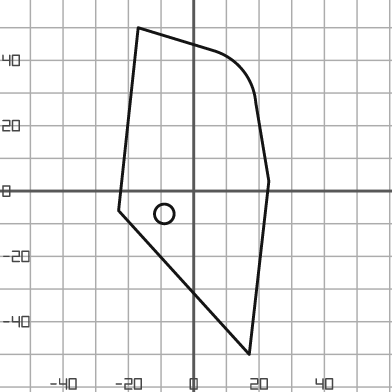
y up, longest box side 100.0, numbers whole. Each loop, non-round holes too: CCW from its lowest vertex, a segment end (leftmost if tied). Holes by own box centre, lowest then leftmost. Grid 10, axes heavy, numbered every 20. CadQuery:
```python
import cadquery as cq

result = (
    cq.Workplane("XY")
    .moveTo(17.0, -50.0)
    .lineTo(23.0, 3.0)
    .lineTo(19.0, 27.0)
    .threePointArc((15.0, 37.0), (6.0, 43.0))
    .lineTo(-17.0, 50.0)
    .lineTo(-23.0, -6.0)
    .close()
    .moveTo(-9.0, -7.0)
    .circle(3.0)
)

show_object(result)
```